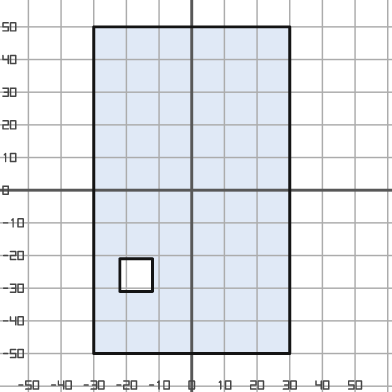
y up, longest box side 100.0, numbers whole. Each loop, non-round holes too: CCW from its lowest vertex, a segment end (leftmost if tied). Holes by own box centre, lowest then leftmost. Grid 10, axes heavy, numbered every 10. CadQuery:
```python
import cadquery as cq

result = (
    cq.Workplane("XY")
    .moveTo(-30.0, -50.0)
    .lineTo(30.0, -50.0)
    .lineTo(30.0, 50.0)
    .lineTo(-30.0, 50.0)
    .close()
    .moveTo(-22.0, -31.0)
    .lineTo(-12.0, -31.0)
    .lineTo(-12.0, -21.0)
    .lineTo(-22.0, -21.0)
    .close()
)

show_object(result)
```